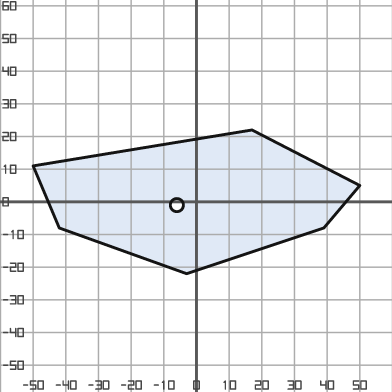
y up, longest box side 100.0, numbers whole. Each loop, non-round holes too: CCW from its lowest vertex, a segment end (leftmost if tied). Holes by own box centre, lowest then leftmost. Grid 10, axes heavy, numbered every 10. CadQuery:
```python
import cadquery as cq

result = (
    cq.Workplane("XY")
    .moveTo(-3.0, -22.0)
    .lineTo(39.0, -8.0)
    .lineTo(50.0, 5.0)
    .lineTo(17.0, 22.0)
    .lineTo(-50.0, 11.0)
    .lineTo(-42.0, -8.0)
    .close()
    .moveTo(-6.0, -1.0)
    .circle(2.0)
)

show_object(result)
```